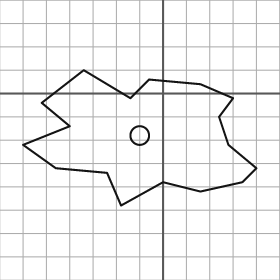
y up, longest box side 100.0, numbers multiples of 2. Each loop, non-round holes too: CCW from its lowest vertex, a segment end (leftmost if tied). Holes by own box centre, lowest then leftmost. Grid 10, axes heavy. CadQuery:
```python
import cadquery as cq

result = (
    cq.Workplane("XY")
    .moveTo(-18.0, -48.0)
    .lineTo(0.0, -38.0)
    .lineTo(16.0, -42.0)
    .lineTo(34.0, -38.0)
    .lineTo(40.0, -32.0)
    .lineTo(28.0, -22.0)
    .lineTo(24.0, -10.0)
    .lineTo(30.0, -2.0)
    .lineTo(16.0, 4.0)
    .lineTo(-6.0, 6.0)
    .lineTo(-14.0, -2.0)
    .lineTo(-34.0, 10.0)
    .lineTo(-52.0, -4.0)
    .lineTo(-40.0, -14.0)
    .lineTo(-60.0, -22.0)
    .lineTo(-46.0, -32.0)
    .lineTo(-24.0, -34.0)
    .close()
    .moveTo(-10.0, -18.0)
    .circle(4.0)
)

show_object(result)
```